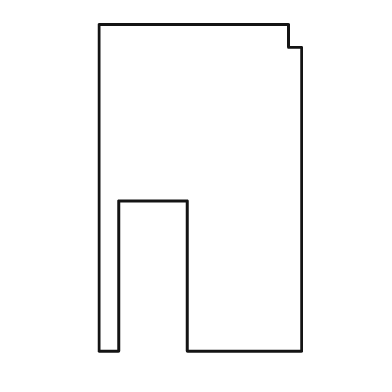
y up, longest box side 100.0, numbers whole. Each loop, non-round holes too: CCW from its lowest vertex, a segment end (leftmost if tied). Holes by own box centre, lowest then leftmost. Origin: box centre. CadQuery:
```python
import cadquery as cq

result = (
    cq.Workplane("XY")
    .moveTo(-31.0, -50.0)
    .lineTo(-25.0, -50.0)
    .lineTo(-25.0, -4.0)
    .lineTo(-4.0, -4.0)
    .lineTo(-4.0, -50.0)
    .lineTo(31.0, -50.0)
    .lineTo(31.0, 43.0)
    .lineTo(27.0, 43.0)
    .lineTo(27.0, 50.0)
    .lineTo(-31.0, 50.0)
    .close()
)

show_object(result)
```